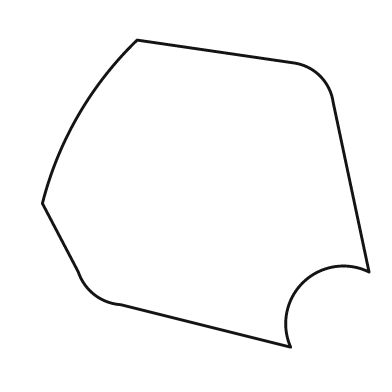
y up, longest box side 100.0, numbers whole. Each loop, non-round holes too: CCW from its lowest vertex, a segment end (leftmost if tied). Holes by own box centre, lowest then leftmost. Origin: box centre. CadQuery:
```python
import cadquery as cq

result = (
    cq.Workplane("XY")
    .moveTo(26.0, -47.0)
    .threePointArc((30.0, -27.0), (50.0, -24.0))
    .lineTo(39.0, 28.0)
    .threePointArc((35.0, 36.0), (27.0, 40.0))
    .lineTo(-21.0, 47.0)
    .threePointArc((-39.0, 24.0), (-50.0, -3.0))
    .lineTo(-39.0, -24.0)
    .threePointArc((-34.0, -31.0), (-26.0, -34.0))
    .close()
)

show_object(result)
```